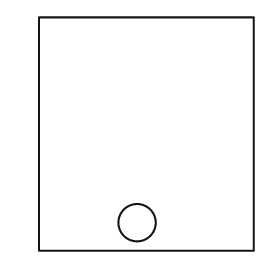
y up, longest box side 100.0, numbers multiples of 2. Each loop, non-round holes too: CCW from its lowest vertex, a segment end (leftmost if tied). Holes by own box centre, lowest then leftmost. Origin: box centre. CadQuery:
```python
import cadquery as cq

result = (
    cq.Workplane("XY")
    .moveTo(-46.0, -50.0)
    .lineTo(46.0, -50.0)
    .lineTo(46.0, 50.0)
    .lineTo(-46.0, 50.0)
    .close()
    .moveTo(-4.0, -38.0)
    .circle(8.0)
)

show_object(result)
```